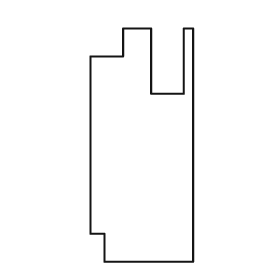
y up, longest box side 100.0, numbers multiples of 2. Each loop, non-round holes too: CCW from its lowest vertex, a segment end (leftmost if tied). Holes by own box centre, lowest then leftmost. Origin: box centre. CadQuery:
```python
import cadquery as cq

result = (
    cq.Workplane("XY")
    .moveTo(-16.0, -50.0)
    .lineTo(22.0, -50.0)
    .lineTo(22.0, 50.0)
    .lineTo(18.0, 50.0)
    .lineTo(18.0, 22.0)
    .lineTo(4.0, 22.0)
    .lineTo(4.0, 50.0)
    .lineTo(-8.0, 50.0)
    .lineTo(-8.0, 38.0)
    .lineTo(-22.0, 38.0)
    .lineTo(-22.0, -38.0)
    .lineTo(-16.0, -38.0)
    .close()
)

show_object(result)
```